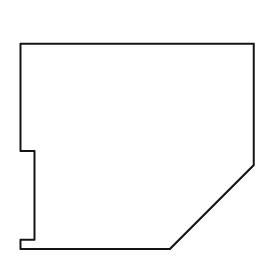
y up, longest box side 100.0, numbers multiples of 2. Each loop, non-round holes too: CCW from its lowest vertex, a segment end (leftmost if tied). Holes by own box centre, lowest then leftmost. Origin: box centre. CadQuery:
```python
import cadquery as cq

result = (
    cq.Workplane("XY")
    .moveTo(-50.0, -44.0)
    .lineTo(14.0, -44.0)
    .lineTo(50.0, -8.0)
    .lineTo(50.0, 44.0)
    .lineTo(-50.0, 44.0)
    .lineTo(-50.0, -2.0)
    .lineTo(-44.0, -2.0)
    .lineTo(-44.0, -40.0)
    .lineTo(-50.0, -40.0)
    .close()
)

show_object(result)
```